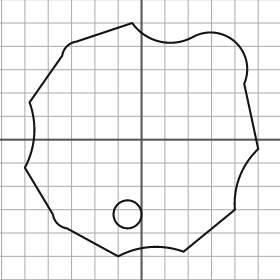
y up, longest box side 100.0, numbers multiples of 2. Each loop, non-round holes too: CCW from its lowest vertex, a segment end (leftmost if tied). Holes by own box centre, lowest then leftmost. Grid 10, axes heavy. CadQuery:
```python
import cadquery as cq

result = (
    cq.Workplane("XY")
    .moveTo(-10.0, -50.0)
    .threePointArc((4.0, -46.0), (18.0, -48.0))
    .lineTo(40.0, -30.0)
    .threePointArc((42.0, -16.0), (50.0, -4.0))
    .lineTo(44.0, 24.0)
    .threePointArc((40.0, 42.0), (22.0, 44.0))
    .threePointArc((8.0, 42.0), (-4.0, 50.0))
    .lineTo(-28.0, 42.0)
    .threePointArc((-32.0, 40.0), (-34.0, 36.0))
    .lineTo(-48.0, 16.0)
    .threePointArc((-46.0, 2.0), (-50.0, -12.0))
    .lineTo(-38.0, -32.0)
    .threePointArc((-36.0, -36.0), (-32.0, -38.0))
    .close()
    .moveTo(-6.0, -32.0)
    .circle(6.0)
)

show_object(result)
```